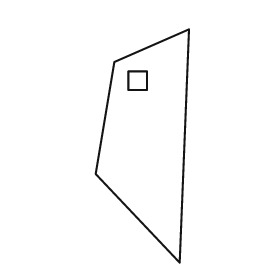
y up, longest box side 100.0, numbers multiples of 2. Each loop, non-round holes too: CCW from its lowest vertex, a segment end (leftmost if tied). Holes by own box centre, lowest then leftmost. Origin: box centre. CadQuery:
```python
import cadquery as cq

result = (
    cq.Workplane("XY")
    .moveTo(16.0, -50.0)
    .lineTo(20.0, 50.0)
    .lineTo(-12.0, 36.0)
    .lineTo(-20.0, -12.0)
    .close()
    .moveTo(-6.0, 24.0)
    .lineTo(2.0, 24.0)
    .lineTo(2.0, 32.0)
    .lineTo(-6.0, 32.0)
    .close()
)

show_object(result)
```